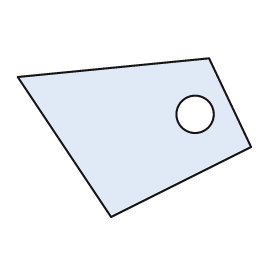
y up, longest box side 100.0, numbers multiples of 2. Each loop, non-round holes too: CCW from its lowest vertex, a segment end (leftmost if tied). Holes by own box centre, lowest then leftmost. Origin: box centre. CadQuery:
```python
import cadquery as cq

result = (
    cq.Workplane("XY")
    .moveTo(-10.0, -34.0)
    .lineTo(50.0, -4.0)
    .lineTo(32.0, 34.0)
    .lineTo(-50.0, 26.0)
    .close()
    .moveTo(26.0, 10.0)
    .circle(8.0)
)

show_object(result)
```